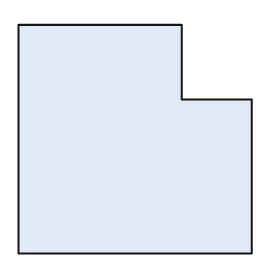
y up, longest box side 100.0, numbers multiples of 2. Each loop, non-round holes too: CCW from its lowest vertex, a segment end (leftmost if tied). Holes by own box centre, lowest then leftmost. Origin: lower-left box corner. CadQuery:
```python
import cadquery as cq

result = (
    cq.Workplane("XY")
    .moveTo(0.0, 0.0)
    .lineTo(100.0, 0.0)
    .lineTo(100.0, 66.0)
    .lineTo(70.0, 66.0)
    .lineTo(70.0, 98.0)
    .lineTo(0.0, 98.0)
    .close()
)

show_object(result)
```